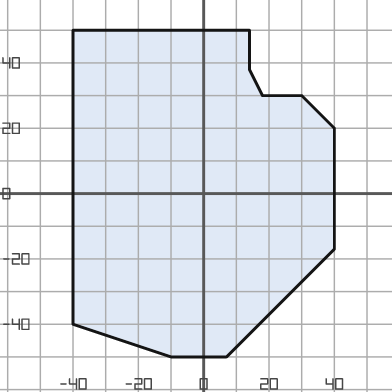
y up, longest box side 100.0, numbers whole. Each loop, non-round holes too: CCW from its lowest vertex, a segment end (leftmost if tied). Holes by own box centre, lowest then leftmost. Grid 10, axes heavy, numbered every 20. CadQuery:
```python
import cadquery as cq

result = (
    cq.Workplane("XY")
    .moveTo(-10.0, -50.0)
    .lineTo(7.0, -50.0)
    .lineTo(40.0, -17.0)
    .lineTo(40.0, 20.0)
    .lineTo(30.0, 30.0)
    .lineTo(18.0, 30.0)
    .lineTo(14.0, 38.0)
    .lineTo(14.0, 50.0)
    .lineTo(-40.0, 50.0)
    .lineTo(-40.0, -40.0)
    .close()
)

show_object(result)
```